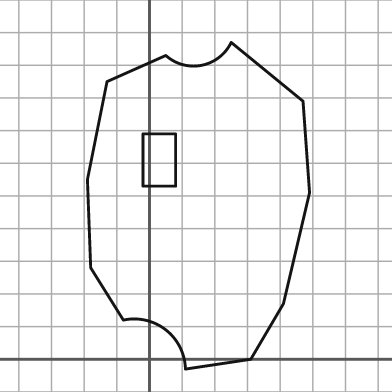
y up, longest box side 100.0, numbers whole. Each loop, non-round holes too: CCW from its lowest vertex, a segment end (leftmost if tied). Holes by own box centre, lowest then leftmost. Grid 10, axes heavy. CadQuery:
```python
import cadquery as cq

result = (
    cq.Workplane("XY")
    .moveTo(11.0, -3.0)
    .lineTo(31.0, 0.0)
    .lineTo(41.0, 17.0)
    .lineTo(49.0, 51.0)
    .lineTo(47.0, 79.0)
    .lineTo(25.0, 97.0)
    .threePointArc((16.0, 90.0), (5.0, 93.0))
    .lineTo(-13.0, 85.0)
    .lineTo(-19.0, 55.0)
    .lineTo(-18.0, 28.0)
    .lineTo(-8.0, 12.0)
    .threePointArc((5.0, 9.0), (11.0, -3.0))
    .close()
    .moveTo(-2.0, 53.0)
    .lineTo(8.0, 53.0)
    .lineTo(8.0, 69.0)
    .lineTo(-2.0, 69.0)
    .close()
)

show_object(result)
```